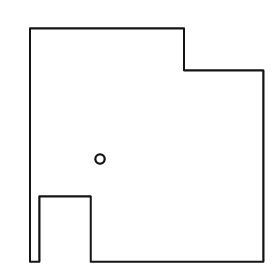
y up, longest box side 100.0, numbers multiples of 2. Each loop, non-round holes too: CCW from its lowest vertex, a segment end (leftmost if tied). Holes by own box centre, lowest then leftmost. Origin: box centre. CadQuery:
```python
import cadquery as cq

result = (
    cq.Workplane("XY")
    .moveTo(-50.0, -50.0)
    .lineTo(-46.0, -50.0)
    .lineTo(-46.0, -22.0)
    .lineTo(-24.0, -22.0)
    .lineTo(-24.0, -50.0)
    .lineTo(50.0, -50.0)
    .lineTo(50.0, 32.0)
    .lineTo(16.0, 32.0)
    .lineTo(16.0, 50.0)
    .lineTo(-50.0, 50.0)
    .close()
    .moveTo(-20.0, -6.0)
    .circle(2.0)
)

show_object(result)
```